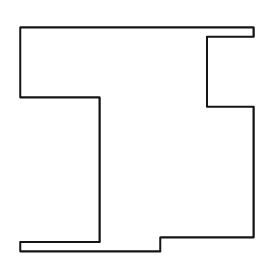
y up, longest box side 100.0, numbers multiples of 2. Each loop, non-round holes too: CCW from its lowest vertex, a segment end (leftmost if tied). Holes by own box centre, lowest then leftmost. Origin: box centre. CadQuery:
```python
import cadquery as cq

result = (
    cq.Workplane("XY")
    .moveTo(-50.0, -48.0)
    .lineTo(10.0, -48.0)
    .lineTo(10.0, -42.0)
    .lineTo(50.0, -42.0)
    .lineTo(50.0, 14.0)
    .lineTo(30.0, 14.0)
    .lineTo(30.0, 44.0)
    .lineTo(50.0, 44.0)
    .lineTo(50.0, 48.0)
    .lineTo(-50.0, 48.0)
    .lineTo(-50.0, 18.0)
    .lineTo(-16.0, 18.0)
    .lineTo(-16.0, -44.0)
    .lineTo(-50.0, -44.0)
    .close()
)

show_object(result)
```